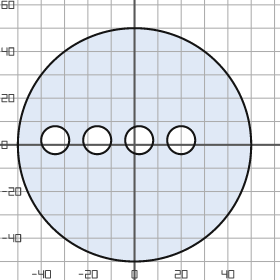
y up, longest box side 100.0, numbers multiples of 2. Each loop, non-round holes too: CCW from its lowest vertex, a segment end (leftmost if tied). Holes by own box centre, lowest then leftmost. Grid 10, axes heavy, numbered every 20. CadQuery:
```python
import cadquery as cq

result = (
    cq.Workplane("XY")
    .moveTo(0.0, 0.0)
    .circle(50.0)
    .moveTo(-34.0, 2.0)
    .circle(6.0)
    .moveTo(-16.0, 2.0)
    .circle(6.0)
    .moveTo(2.0, 2.0)
    .circle(6.0)
    .moveTo(20.0, 2.0)
    .circle(6.0)
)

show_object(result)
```